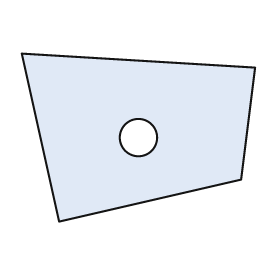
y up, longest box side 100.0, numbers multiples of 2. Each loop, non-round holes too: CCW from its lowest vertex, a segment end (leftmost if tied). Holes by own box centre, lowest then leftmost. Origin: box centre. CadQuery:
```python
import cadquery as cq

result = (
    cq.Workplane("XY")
    .moveTo(-34.0, -36.0)
    .lineTo(44.0, -18.0)
    .lineTo(50.0, 30.0)
    .lineTo(-50.0, 36.0)
    .close()
    .moveTo(0.0, 0.0)
    .circle(8.0)
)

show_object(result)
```